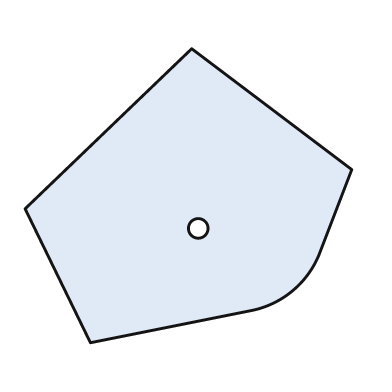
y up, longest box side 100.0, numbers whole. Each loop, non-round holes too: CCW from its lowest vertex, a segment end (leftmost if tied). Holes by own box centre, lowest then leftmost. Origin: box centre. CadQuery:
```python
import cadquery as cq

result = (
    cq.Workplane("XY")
    .moveTo(-30.0, -45.0)
    .lineTo(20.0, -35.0)
    .threePointArc((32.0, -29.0), (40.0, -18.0))
    .lineTo(50.0, 8.0)
    .lineTo(1.0, 45.0)
    .lineTo(-50.0, -4.0)
    .close()
    .moveTo(3.0, -10.0)
    .circle(3.0)
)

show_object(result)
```